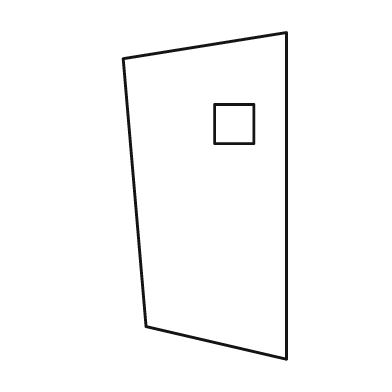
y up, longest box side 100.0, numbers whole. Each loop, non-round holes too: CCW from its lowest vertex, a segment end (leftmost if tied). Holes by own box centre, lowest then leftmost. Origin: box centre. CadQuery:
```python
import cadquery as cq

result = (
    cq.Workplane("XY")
    .moveTo(25.0, -50.0)
    .lineTo(25.0, 50.0)
    .lineTo(-25.0, 42.0)
    .lineTo(-18.0, -40.0)
    .close()
    .moveTo(3.0, 16.0)
    .lineTo(15.0, 16.0)
    .lineTo(15.0, 28.0)
    .lineTo(3.0, 28.0)
    .close()
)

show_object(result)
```